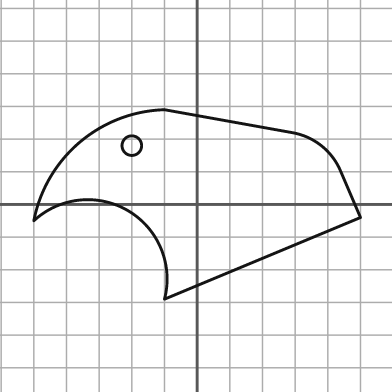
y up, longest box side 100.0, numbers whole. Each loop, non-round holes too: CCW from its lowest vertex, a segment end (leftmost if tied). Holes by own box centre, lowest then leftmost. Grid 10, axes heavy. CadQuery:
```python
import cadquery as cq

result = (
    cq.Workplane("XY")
    .moveTo(-10.0, -29.0)
    .lineTo(50.0, -4.0)
    .lineTo(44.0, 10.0)
    .threePointArc((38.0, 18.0), (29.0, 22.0))
    .lineTo(-10.0, 29.0)
    .threePointArc((-36.0, 19.0), (-50.0, -5.0))
    .threePointArc((-21.0, -2.0), (-10.0, -29.0))
    .close()
    .moveTo(-20.0, 18.0)
    .circle(3.0)
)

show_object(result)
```